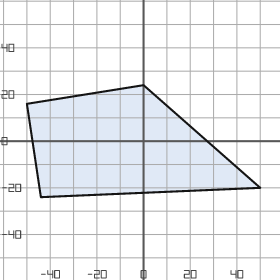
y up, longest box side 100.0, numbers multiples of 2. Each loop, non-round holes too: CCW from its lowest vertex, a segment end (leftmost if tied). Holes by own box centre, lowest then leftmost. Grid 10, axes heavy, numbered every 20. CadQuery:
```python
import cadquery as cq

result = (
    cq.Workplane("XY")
    .moveTo(-44.0, -24.0)
    .lineTo(50.0, -20.0)
    .lineTo(0.0, 24.0)
    .lineTo(-50.0, 16.0)
    .close()
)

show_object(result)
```